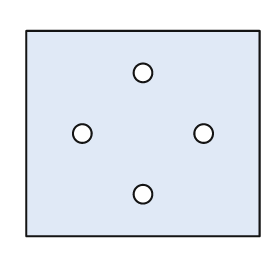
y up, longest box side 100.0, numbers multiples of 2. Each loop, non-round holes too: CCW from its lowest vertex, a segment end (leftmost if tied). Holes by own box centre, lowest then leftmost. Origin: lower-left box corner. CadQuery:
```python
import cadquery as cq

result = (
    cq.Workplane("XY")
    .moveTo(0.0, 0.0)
    .lineTo(100.0, 0.0)
    .lineTo(100.0, 88.0)
    .lineTo(0.0, 88.0)
    .close()
    .moveTo(50.0, 18.0)
    .circle(4.0)
    .moveTo(24.0, 44.0)
    .circle(4.0)
    .moveTo(76.0, 44.0)
    .circle(4.0)
    .moveTo(50.0, 70.0)
    .circle(4.0)
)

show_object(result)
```